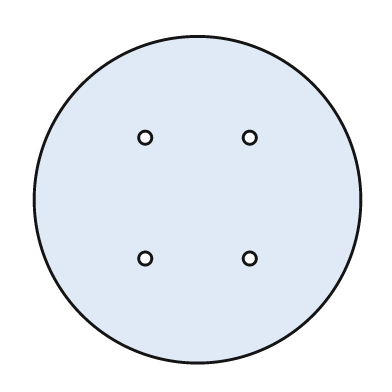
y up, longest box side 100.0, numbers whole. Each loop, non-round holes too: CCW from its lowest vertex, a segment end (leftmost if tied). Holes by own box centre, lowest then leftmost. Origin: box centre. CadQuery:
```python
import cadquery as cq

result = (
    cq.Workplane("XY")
    .moveTo(0.0, 0.0)
    .circle(50.0)
    .moveTo(-16.0, -18.0)
    .circle(2.0)
    .moveTo(16.0, -18.0)
    .circle(2.0)
    .moveTo(-16.0, 19.0)
    .circle(2.0)
    .moveTo(16.0, 19.0)
    .circle(2.0)
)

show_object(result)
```